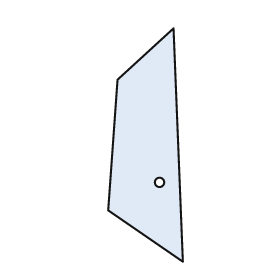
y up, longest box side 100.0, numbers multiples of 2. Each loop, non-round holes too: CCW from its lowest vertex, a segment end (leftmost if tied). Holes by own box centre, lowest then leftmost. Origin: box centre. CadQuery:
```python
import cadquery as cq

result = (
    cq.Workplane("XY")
    .moveTo(16.0, -50.0)
    .lineTo(12.0, 50.0)
    .lineTo(-12.0, 28.0)
    .lineTo(-16.0, -28.0)
    .close()
    .moveTo(6.0, -16.0)
    .circle(2.0)
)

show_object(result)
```